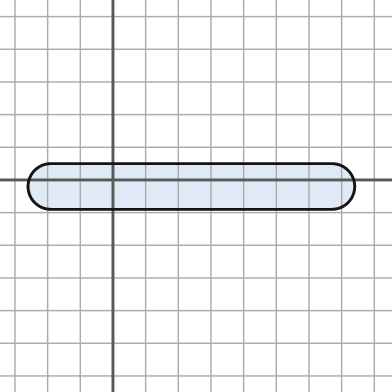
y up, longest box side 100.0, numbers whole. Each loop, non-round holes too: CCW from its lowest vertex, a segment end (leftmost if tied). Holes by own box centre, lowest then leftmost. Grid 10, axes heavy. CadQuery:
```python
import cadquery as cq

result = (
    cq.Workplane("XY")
    .moveTo(-19.0, -9.0)
    .lineTo(67.0, -9.0)
    .threePointArc((74.0, -2.0), (67.0, 5.0))
    .lineTo(-19.0, 5.0)
    .threePointArc((-26.0, -2.0), (-19.0, -9.0))
    .close()
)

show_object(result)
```